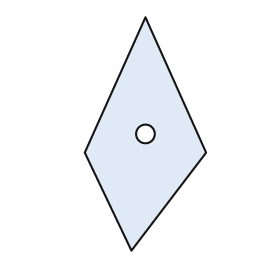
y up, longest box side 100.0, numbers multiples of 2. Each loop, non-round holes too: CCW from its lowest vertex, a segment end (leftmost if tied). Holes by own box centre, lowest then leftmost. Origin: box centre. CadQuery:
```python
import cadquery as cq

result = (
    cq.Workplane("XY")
    .moveTo(-6.0, -50.0)
    .lineTo(26.0, -8.0)
    .lineTo(0.0, 50.0)
    .lineTo(-26.0, -8.0)
    .close()
    .moveTo(0.0, 0.0)
    .circle(4.0)
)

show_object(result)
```